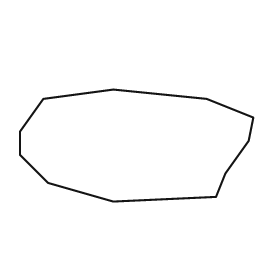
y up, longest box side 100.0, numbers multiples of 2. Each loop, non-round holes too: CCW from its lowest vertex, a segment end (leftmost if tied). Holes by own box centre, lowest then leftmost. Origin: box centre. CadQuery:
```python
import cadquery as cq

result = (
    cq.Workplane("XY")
    .moveTo(-10.0, -24.0)
    .lineTo(34.0, -22.0)
    .lineTo(38.0, -12.0)
    .lineTo(48.0, 2.0)
    .lineTo(50.0, 12.0)
    .lineTo(30.0, 20.0)
    .lineTo(-10.0, 24.0)
    .lineTo(-40.0, 20.0)
    .lineTo(-50.0, 6.0)
    .lineTo(-50.0, -4.0)
    .lineTo(-38.0, -16.0)
    .close()
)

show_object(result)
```